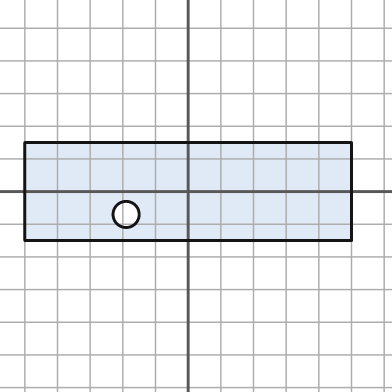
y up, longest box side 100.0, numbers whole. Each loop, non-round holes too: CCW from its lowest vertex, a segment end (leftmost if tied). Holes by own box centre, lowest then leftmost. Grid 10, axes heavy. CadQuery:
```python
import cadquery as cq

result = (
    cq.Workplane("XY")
    .moveTo(-50.0, -15.0)
    .lineTo(50.0, -15.0)
    .lineTo(50.0, 15.0)
    .lineTo(-50.0, 15.0)
    .close()
    .moveTo(-19.0, -7.0)
    .circle(4.0)
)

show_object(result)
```